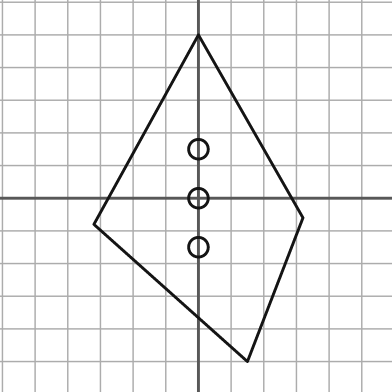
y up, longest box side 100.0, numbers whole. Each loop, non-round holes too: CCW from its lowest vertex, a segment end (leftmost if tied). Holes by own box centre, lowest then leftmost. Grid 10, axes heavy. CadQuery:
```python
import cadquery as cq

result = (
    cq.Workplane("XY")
    .moveTo(15.0, -50.0)
    .lineTo(32.0, -6.0)
    .lineTo(0.0, 50.0)
    .lineTo(-32.0, -8.0)
    .close()
    .moveTo(0.0, -15.0)
    .circle(3.0)
    .moveTo(0.0, 0.0)
    .circle(3.0)
    .moveTo(0.0, 15.0)
    .circle(3.0)
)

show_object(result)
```